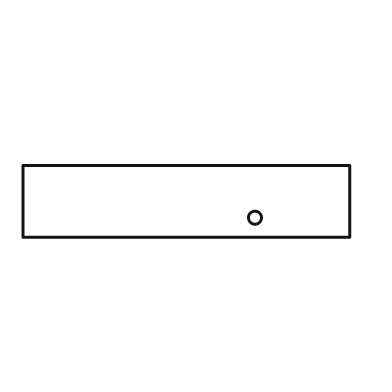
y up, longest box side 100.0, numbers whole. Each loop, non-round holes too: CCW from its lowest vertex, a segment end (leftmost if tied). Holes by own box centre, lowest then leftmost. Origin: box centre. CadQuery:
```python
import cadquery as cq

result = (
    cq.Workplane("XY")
    .moveTo(-50.0, -11.0)
    .lineTo(50.0, -11.0)
    .lineTo(50.0, 11.0)
    .lineTo(-50.0, 11.0)
    .close()
    .moveTo(21.0, -5.0)
    .circle(2.0)
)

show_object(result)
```